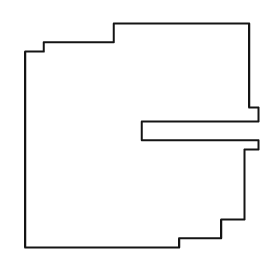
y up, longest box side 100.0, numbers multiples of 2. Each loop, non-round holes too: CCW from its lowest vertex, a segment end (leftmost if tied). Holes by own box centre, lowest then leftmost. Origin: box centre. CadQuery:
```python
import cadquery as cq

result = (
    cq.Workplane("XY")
    .moveTo(-50.0, -48.0)
    .lineTo(16.0, -48.0)
    .lineTo(16.0, -44.0)
    .lineTo(34.0, -44.0)
    .lineTo(34.0, -36.0)
    .lineTo(44.0, -36.0)
    .lineTo(44.0, -6.0)
    .lineTo(50.0, -6.0)
    .lineTo(50.0, -2.0)
    .lineTo(0.0, -2.0)
    .lineTo(0.0, 6.0)
    .lineTo(50.0, 6.0)
    .lineTo(50.0, 12.0)
    .lineTo(46.0, 12.0)
    .lineTo(46.0, 48.0)
    .lineTo(-12.0, 48.0)
    .lineTo(-12.0, 40.0)
    .lineTo(-42.0, 40.0)
    .lineTo(-42.0, 36.0)
    .lineTo(-50.0, 36.0)
    .close()
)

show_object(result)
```